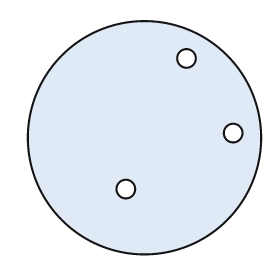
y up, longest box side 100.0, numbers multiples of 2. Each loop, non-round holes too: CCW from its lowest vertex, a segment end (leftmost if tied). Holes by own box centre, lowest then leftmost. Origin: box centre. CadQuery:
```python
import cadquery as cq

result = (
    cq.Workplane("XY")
    .moveTo(0.0, 0.0)
    .circle(50.0)
    .moveTo(-8.0, -22.0)
    .circle(4.0)
    .moveTo(38.0, 2.0)
    .circle(4.0)
    .moveTo(18.0, 34.0)
    .circle(4.0)
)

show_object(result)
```